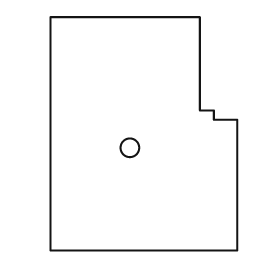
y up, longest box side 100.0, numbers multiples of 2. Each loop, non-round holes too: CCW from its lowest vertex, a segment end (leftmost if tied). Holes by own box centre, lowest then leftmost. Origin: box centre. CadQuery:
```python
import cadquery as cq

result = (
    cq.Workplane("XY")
    .moveTo(-40.0, -50.0)
    .lineTo(40.0, -50.0)
    .lineTo(40.0, 6.0)
    .lineTo(30.0, 6.0)
    .lineTo(30.0, 10.0)
    .lineTo(24.0, 10.0)
    .lineTo(24.0, 50.0)
    .lineTo(-40.0, 50.0)
    .close()
    .moveTo(-6.0, -6.0)
    .circle(4.0)
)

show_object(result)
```